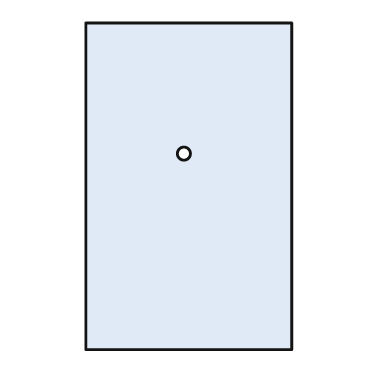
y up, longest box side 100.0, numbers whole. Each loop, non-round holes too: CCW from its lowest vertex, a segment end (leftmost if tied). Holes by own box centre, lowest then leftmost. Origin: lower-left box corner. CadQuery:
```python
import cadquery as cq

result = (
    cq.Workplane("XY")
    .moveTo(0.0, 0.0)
    .lineTo(63.0, 0.0)
    .lineTo(63.0, 100.0)
    .lineTo(0.0, 100.0)
    .close()
    .moveTo(30.0, 60.0)
    .circle(2.0)
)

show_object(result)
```